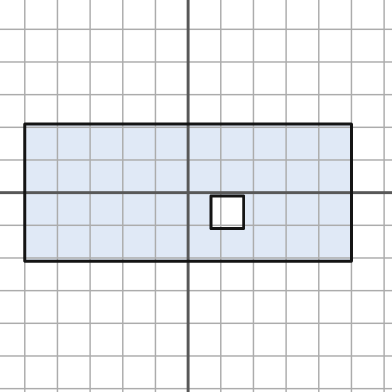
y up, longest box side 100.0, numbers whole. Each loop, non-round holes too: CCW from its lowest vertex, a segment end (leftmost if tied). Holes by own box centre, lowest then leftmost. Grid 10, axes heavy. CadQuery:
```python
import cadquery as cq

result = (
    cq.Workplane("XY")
    .moveTo(-50.0, -21.0)
    .lineTo(50.0, -21.0)
    .lineTo(50.0, 21.0)
    .lineTo(-50.0, 21.0)
    .close()
    .moveTo(7.0, -11.0)
    .lineTo(17.0, -11.0)
    .lineTo(17.0, -1.0)
    .lineTo(7.0, -1.0)
    .close()
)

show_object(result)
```